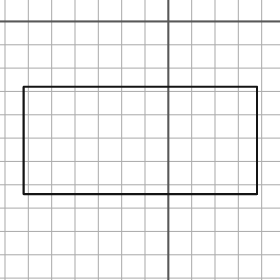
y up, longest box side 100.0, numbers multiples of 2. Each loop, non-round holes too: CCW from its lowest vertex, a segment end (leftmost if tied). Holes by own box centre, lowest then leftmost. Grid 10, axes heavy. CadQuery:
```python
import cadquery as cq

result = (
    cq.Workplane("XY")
    .moveTo(-62.0, -74.0)
    .lineTo(38.0, -74.0)
    .lineTo(38.0, -28.0)
    .lineTo(-62.0, -28.0)
    .close()
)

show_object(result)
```